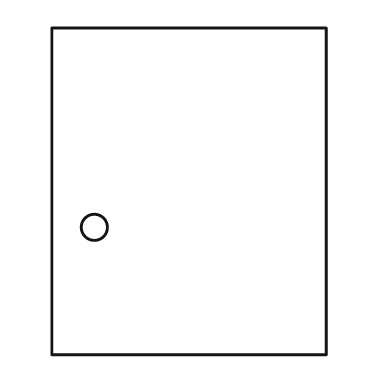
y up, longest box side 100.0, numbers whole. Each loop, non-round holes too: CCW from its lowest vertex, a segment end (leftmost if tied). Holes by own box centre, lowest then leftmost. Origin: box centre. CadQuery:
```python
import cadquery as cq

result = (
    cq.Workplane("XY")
    .moveTo(-42.0, -50.0)
    .lineTo(42.0, -50.0)
    .lineTo(42.0, 50.0)
    .lineTo(-42.0, 50.0)
    .close()
    .moveTo(-29.0, -11.0)
    .circle(4.0)
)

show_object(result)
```